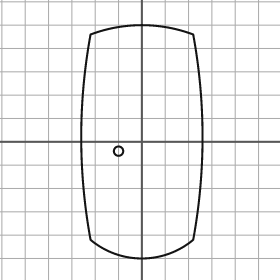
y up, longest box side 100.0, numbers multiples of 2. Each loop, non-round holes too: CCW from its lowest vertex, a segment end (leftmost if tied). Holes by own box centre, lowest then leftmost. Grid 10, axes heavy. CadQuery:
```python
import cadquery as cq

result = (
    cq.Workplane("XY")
    .moveTo(-22.0, -42.0)
    .threePointArc((0.0, -50.0), (22.0, -42.0))
    .threePointArc((26.0, 2.0), (22.0, 46.0))
    .threePointArc((0.0, 50.0), (-22.0, 46.0))
    .threePointArc((-26.0, 2.0), (-22.0, -42.0))
    .close()
    .moveTo(-10.0, -4.0)
    .circle(2.0)
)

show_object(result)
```